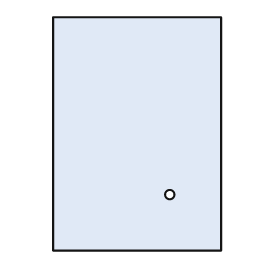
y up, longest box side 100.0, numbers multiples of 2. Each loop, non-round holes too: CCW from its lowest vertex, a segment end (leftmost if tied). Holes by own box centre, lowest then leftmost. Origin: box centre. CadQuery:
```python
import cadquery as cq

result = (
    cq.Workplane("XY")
    .moveTo(-36.0, -50.0)
    .lineTo(36.0, -50.0)
    .lineTo(36.0, 50.0)
    .lineTo(-36.0, 50.0)
    .close()
    .moveTo(14.0, -26.0)
    .circle(2.0)
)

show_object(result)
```